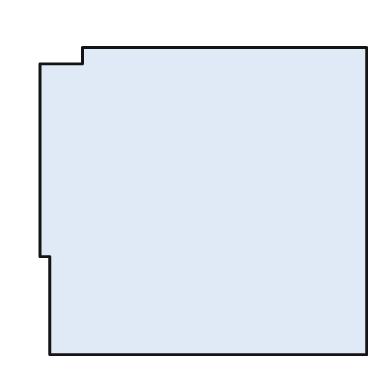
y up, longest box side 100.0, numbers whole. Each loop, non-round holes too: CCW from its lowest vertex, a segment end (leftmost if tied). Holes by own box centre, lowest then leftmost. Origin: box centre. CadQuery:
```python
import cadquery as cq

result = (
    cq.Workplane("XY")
    .moveTo(-47.0, -47.0)
    .lineTo(50.0, -47.0)
    .lineTo(50.0, 47.0)
    .lineTo(-37.0, 47.0)
    .lineTo(-37.0, 42.0)
    .lineTo(-50.0, 42.0)
    .lineTo(-50.0, -17.0)
    .lineTo(-47.0, -17.0)
    .close()
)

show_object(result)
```